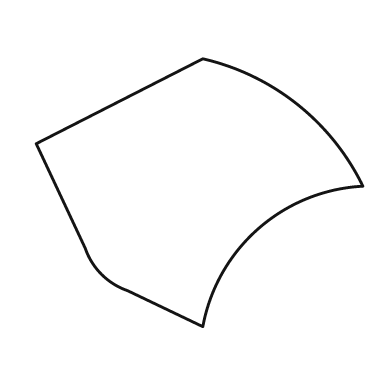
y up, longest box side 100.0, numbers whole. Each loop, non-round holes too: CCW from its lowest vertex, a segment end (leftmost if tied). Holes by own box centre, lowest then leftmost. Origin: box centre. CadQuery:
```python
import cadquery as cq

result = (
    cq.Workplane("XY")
    .moveTo(1.0, -41.0)
    .threePointArc((18.0, -11.0), (50.0, 2.0))
    .threePointArc((30.0, 27.0), (1.0, 41.0))
    .lineTo(-50.0, 15.0)
    .lineTo(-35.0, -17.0)
    .threePointArc((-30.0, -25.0), (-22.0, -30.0))
    .close()
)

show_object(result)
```